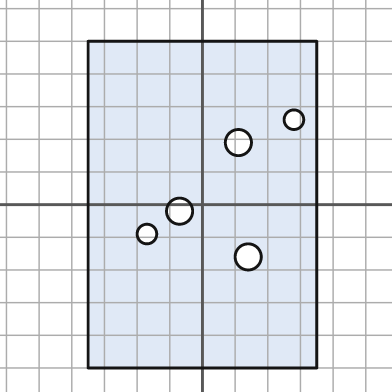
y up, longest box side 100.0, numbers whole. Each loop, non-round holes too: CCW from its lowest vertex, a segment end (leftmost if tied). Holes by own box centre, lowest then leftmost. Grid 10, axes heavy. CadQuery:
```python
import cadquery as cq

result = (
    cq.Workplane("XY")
    .moveTo(-35.0, -50.0)
    .lineTo(35.0, -50.0)
    .lineTo(35.0, 50.0)
    .lineTo(-35.0, 50.0)
    .close()
    .moveTo(14.0, -16.0)
    .circle(4.0)
    .moveTo(-17.0, -9.0)
    .circle(3.0)
    .moveTo(-7.0, -2.0)
    .circle(4.0)
    .moveTo(11.0, 19.0)
    .circle(4.0)
    .moveTo(28.0, 26.0)
    .circle(3.0)
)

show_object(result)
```